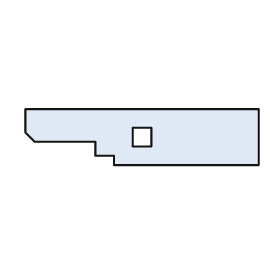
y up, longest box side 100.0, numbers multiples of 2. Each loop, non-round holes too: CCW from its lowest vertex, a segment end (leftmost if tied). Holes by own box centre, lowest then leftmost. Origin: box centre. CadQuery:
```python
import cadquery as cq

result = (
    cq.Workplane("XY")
    .moveTo(-12.0, -12.0)
    .lineTo(50.0, -12.0)
    .lineTo(50.0, 12.0)
    .lineTo(-50.0, 12.0)
    .lineTo(-50.0, 2.0)
    .lineTo(-46.0, -2.0)
    .lineTo(-20.0, -2.0)
    .lineTo(-20.0, -8.0)
    .lineTo(-12.0, -8.0)
    .close()
    .moveTo(-4.0, -4.0)
    .lineTo(4.0, -4.0)
    .lineTo(4.0, 4.0)
    .lineTo(-4.0, 4.0)
    .close()
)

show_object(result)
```